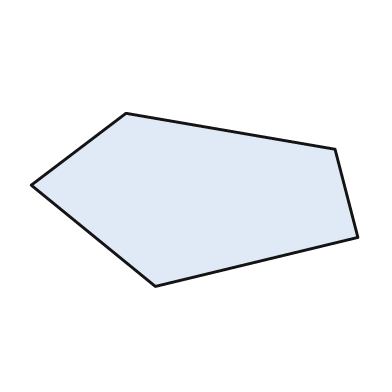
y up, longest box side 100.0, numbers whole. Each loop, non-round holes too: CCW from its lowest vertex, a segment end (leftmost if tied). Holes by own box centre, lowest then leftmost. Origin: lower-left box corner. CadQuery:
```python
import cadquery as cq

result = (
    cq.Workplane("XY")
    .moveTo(38.0, 0.0)
    .lineTo(100.0, 15.0)
    .lineTo(93.0, 42.0)
    .lineTo(29.0, 53.0)
    .lineTo(0.0, 31.0)
    .close()
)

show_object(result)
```